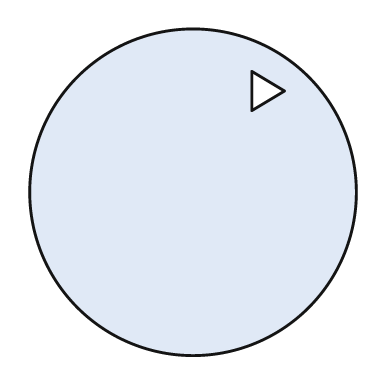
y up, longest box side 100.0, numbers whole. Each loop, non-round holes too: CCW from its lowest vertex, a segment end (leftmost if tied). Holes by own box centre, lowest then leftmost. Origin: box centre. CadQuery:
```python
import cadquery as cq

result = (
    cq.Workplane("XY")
    .moveTo(0.0, 0.0)
    .circle(50.0)
    .moveTo(18.0, 25.0)
    .lineTo(28.0, 31.0)
    .lineTo(18.0, 37.0)
    .close()
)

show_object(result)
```